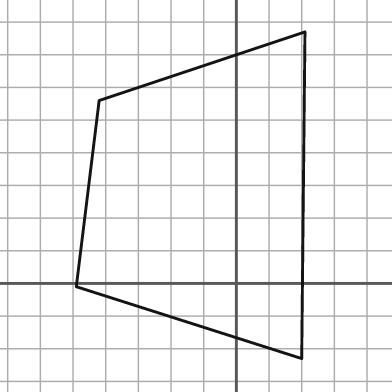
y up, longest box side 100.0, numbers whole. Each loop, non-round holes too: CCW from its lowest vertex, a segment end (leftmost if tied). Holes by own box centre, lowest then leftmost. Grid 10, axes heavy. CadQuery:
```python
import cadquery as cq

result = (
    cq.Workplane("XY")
    .moveTo(20.0, -23.0)
    .lineTo(21.0, 77.0)
    .lineTo(-42.0, 56.0)
    .lineTo(-49.0, -1.0)
    .close()
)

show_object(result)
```